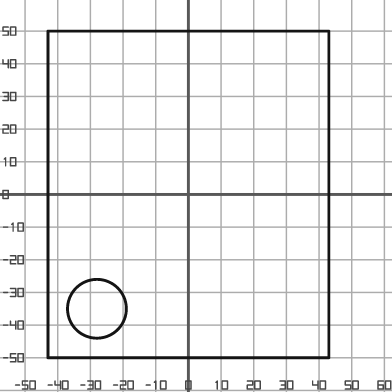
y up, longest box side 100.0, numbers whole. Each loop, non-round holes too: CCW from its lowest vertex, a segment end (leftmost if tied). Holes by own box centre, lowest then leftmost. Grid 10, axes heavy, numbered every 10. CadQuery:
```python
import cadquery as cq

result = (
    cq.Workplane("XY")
    .moveTo(-43.0, -50.0)
    .lineTo(43.0, -50.0)
    .lineTo(43.0, 50.0)
    .lineTo(-43.0, 50.0)
    .close()
    .moveTo(-28.0, -35.0)
    .circle(9.0)
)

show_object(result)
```